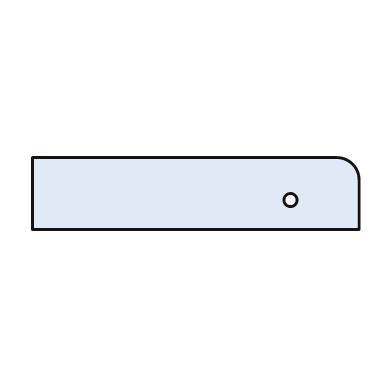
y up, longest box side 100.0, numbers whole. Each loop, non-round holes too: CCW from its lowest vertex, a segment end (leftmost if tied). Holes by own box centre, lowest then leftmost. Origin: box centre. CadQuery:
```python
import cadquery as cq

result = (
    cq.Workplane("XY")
    .moveTo(-50.0, -11.0)
    .lineTo(50.0, -11.0)
    .lineTo(50.0, 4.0)
    .threePointArc((48.0, 9.0), (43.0, 11.0))
    .lineTo(-50.0, 11.0)
    .close()
    .moveTo(29.0, -2.0)
    .circle(2.0)
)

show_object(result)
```